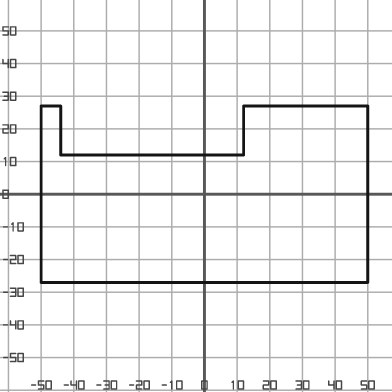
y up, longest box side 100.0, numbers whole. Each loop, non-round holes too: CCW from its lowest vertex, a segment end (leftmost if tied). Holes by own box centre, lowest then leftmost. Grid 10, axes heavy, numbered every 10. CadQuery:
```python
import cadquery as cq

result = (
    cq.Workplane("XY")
    .moveTo(-50.0, -27.0)
    .lineTo(50.0, -27.0)
    .lineTo(50.0, 27.0)
    .lineTo(12.0, 27.0)
    .lineTo(12.0, 12.0)
    .lineTo(-44.0, 12.0)
    .lineTo(-44.0, 27.0)
    .lineTo(-50.0, 27.0)
    .close()
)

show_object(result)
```